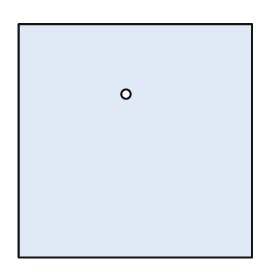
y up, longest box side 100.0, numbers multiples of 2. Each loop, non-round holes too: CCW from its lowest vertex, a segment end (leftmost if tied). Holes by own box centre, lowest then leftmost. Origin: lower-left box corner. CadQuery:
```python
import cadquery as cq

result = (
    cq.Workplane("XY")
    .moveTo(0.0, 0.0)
    .lineTo(100.0, 0.0)
    .lineTo(100.0, 100.0)
    .lineTo(0.0, 100.0)
    .close()
    .moveTo(46.0, 70.0)
    .circle(2.0)
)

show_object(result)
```